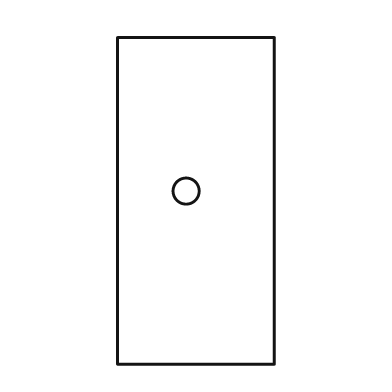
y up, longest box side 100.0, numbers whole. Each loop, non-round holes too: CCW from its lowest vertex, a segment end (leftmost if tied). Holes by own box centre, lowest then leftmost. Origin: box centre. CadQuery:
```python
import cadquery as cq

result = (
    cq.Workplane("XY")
    .moveTo(-24.0, -50.0)
    .lineTo(24.0, -50.0)
    .lineTo(24.0, 50.0)
    .lineTo(-24.0, 50.0)
    .close()
    .moveTo(-3.0, 3.0)
    .circle(4.0)
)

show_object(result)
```